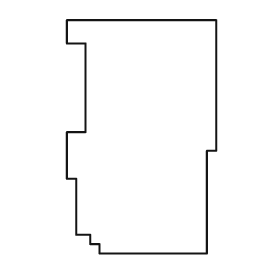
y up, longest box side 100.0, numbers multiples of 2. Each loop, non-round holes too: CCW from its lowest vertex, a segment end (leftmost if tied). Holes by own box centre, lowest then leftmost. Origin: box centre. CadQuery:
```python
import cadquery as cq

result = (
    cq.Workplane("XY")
    .moveTo(-18.0, -50.0)
    .lineTo(28.0, -50.0)
    .lineTo(28.0, -6.0)
    .lineTo(32.0, -6.0)
    .lineTo(32.0, 50.0)
    .lineTo(-32.0, 50.0)
    .lineTo(-32.0, 40.0)
    .lineTo(-24.0, 40.0)
    .lineTo(-24.0, 2.0)
    .lineTo(-32.0, 2.0)
    .lineTo(-32.0, -18.0)
    .lineTo(-28.0, -18.0)
    .lineTo(-28.0, -42.0)
    .lineTo(-22.0, -42.0)
    .lineTo(-22.0, -46.0)
    .lineTo(-18.0, -46.0)
    .close()
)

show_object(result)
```